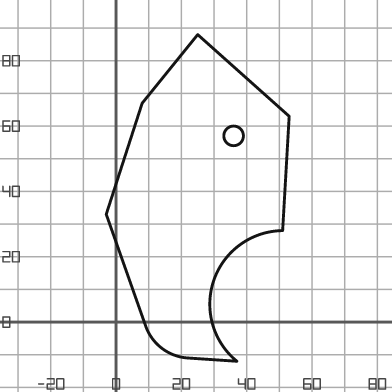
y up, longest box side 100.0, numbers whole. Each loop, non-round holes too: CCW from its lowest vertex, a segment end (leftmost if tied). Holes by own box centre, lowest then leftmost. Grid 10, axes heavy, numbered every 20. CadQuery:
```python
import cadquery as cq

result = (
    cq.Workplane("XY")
    .moveTo(37.0, -12.0)
    .threePointArc((30.0, 13.0), (51.0, 28.0))
    .lineTo(53.0, 63.0)
    .lineTo(25.0, 88.0)
    .lineTo(8.0, 67.0)
    .lineTo(-3.0, 33.0)
    .lineTo(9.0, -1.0)
    .threePointArc((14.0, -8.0), (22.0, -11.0))
    .close()
    .moveTo(36.0, 57.0)
    .circle(3.0)
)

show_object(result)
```